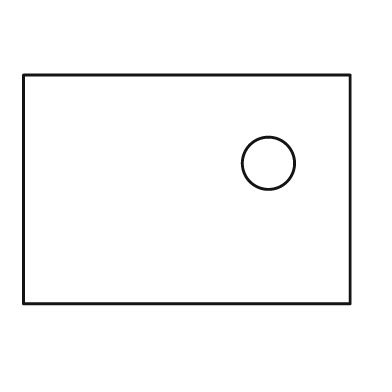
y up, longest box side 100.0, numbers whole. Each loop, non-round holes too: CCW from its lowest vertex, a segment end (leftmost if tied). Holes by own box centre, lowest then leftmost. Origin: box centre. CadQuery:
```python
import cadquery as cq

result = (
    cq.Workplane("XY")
    .moveTo(-50.0, -35.0)
    .lineTo(50.0, -35.0)
    .lineTo(50.0, 35.0)
    .lineTo(-50.0, 35.0)
    .close()
    .moveTo(25.0, 8.0)
    .circle(8.0)
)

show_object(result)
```